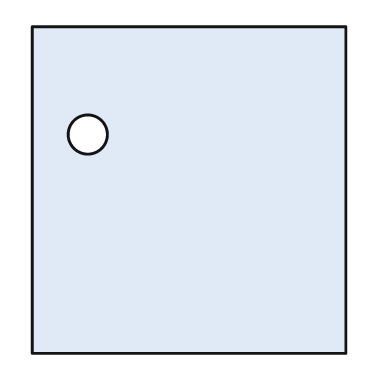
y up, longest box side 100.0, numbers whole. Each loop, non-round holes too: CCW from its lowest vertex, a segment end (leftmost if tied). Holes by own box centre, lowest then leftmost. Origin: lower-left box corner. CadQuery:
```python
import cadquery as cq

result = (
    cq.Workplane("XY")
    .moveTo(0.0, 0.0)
    .lineTo(96.0, 0.0)
    .lineTo(96.0, 100.0)
    .lineTo(0.0, 100.0)
    .close()
    .moveTo(17.0, 67.0)
    .circle(6.0)
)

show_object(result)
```